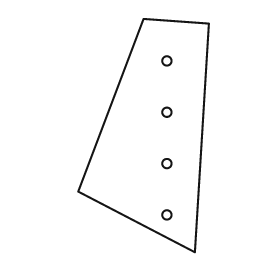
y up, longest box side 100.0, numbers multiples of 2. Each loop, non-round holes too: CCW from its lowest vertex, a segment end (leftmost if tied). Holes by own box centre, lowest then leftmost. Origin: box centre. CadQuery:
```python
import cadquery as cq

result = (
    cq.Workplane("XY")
    .moveTo(22.0, -50.0)
    .lineTo(28.0, 48.0)
    .lineTo(0.0, 50.0)
    .lineTo(-28.0, -24.0)
    .close()
    .moveTo(10.0, -34.0)
    .circle(2.0)
    .moveTo(10.0, -12.0)
    .circle(2.0)
    .moveTo(10.0, 10.0)
    .circle(2.0)
    .moveTo(10.0, 32.0)
    .circle(2.0)
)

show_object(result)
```